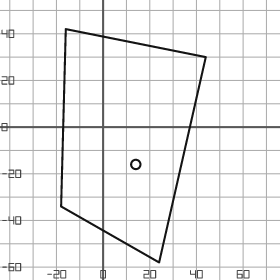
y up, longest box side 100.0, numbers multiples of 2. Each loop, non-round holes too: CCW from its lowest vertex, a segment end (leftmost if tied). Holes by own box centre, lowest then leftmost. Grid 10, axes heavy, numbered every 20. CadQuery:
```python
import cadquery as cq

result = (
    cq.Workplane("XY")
    .moveTo(24.0, -58.0)
    .lineTo(44.0, 30.0)
    .lineTo(-16.0, 42.0)
    .lineTo(-18.0, -34.0)
    .close()
    .moveTo(14.0, -16.0)
    .circle(2.0)
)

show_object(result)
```